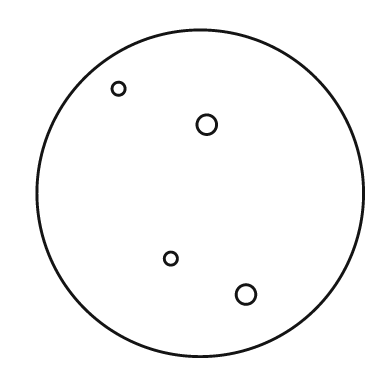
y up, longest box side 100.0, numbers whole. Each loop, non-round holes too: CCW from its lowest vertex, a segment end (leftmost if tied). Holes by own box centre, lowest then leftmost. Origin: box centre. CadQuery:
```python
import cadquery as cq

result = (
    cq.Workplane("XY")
    .moveTo(0.0, 0.0)
    .circle(50.0)
    .moveTo(14.0, -31.0)
    .circle(3.0)
    .moveTo(-9.0, -20.0)
    .circle(2.0)
    .moveTo(2.0, 21.0)
    .circle(3.0)
    .moveTo(-25.0, 32.0)
    .circle(2.0)
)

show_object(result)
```